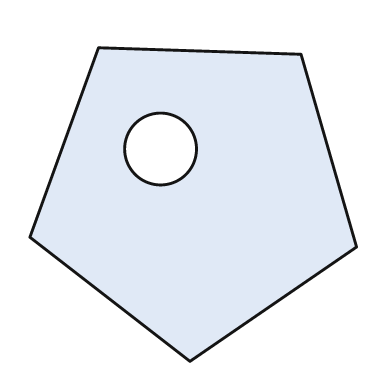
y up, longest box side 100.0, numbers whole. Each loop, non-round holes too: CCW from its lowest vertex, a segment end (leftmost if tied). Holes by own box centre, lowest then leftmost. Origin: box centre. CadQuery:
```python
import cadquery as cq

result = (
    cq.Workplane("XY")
    .moveTo(-1.0, -48.0)
    .lineTo(50.0, -13.0)
    .lineTo(33.0, 46.0)
    .lineTo(-29.0, 48.0)
    .lineTo(-50.0, -10.0)
    .close()
    .moveTo(-10.0, 17.0)
    .circle(11.0)
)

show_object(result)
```